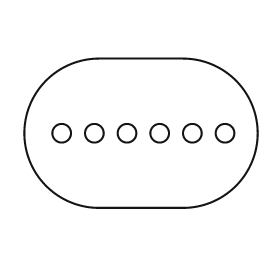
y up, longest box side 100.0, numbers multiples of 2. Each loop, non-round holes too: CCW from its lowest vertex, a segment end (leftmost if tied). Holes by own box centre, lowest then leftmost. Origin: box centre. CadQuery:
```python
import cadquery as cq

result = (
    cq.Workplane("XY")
    .moveTo(-18.0, -32.0)
    .lineTo(18.0, -32.0)
    .threePointArc((50.0, 0.0), (18.0, 32.0))
    .lineTo(-18.0, 32.0)
    .threePointArc((-50.0, 0.0), (-18.0, -32.0))
    .close()
    .moveTo(-34.0, 0.0)
    .circle(4.0)
    .moveTo(-20.0, 0.0)
    .circle(4.0)
    .moveTo(-6.0, 0.0)
    .circle(4.0)
    .moveTo(8.0, 0.0)
    .circle(4.0)
    .moveTo(22.0, 0.0)
    .circle(4.0)
    .moveTo(36.0, 0.0)
    .circle(4.0)
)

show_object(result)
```